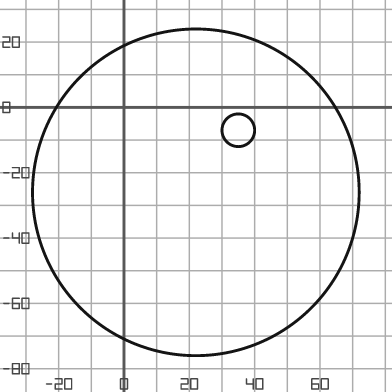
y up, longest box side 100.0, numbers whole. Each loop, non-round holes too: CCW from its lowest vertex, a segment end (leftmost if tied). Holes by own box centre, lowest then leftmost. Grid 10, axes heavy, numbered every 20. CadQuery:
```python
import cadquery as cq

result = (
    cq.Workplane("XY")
    .moveTo(22.0, -26.0)
    .circle(50.0)
    .moveTo(35.0, -7.0)
    .circle(5.0)
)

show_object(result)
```